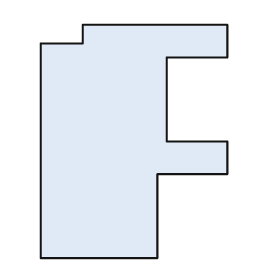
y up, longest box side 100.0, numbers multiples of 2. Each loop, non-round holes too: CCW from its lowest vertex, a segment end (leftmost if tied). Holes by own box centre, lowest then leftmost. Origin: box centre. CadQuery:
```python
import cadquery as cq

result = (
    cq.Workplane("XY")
    .moveTo(-40.0, -50.0)
    .lineTo(10.0, -50.0)
    .lineTo(10.0, -14.0)
    .lineTo(40.0, -14.0)
    .lineTo(40.0, 0.0)
    .lineTo(14.0, 0.0)
    .lineTo(14.0, 36.0)
    .lineTo(40.0, 36.0)
    .lineTo(40.0, 50.0)
    .lineTo(-22.0, 50.0)
    .lineTo(-22.0, 42.0)
    .lineTo(-40.0, 42.0)
    .close()
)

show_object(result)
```